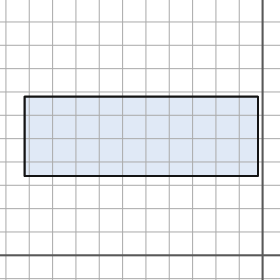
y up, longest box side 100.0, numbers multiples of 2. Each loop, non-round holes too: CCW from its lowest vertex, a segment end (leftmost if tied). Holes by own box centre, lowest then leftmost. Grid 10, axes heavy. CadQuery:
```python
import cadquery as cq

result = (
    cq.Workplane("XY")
    .moveTo(-102.0, 34.0)
    .lineTo(-2.0, 34.0)
    .lineTo(-2.0, 68.0)
    .lineTo(-102.0, 68.0)
    .close()
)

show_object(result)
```